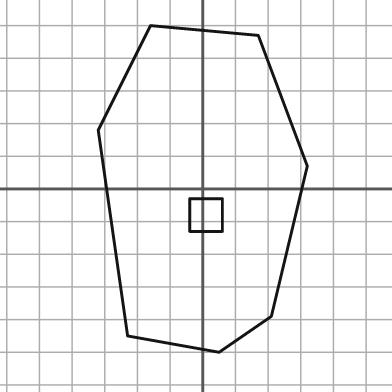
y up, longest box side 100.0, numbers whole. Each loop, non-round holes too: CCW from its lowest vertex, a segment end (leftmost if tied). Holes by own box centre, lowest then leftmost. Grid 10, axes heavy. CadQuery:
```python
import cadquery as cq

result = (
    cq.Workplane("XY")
    .moveTo(5.0, -50.0)
    .lineTo(21.0, -39.0)
    .lineTo(32.0, 7.0)
    .lineTo(17.0, 47.0)
    .lineTo(-16.0, 50.0)
    .lineTo(-32.0, 18.0)
    .lineTo(-23.0, -45.0)
    .close()
    .moveTo(-4.0, -13.0)
    .lineTo(6.0, -13.0)
    .lineTo(6.0, -3.0)
    .lineTo(-4.0, -3.0)
    .close()
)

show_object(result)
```